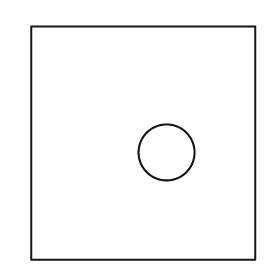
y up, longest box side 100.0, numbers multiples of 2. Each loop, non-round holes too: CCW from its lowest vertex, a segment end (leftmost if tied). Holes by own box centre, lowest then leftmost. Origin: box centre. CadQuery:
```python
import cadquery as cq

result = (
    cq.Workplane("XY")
    .moveTo(-48.0, -50.0)
    .lineTo(48.0, -50.0)
    .lineTo(48.0, 50.0)
    .lineTo(-48.0, 50.0)
    .close()
    .moveTo(10.0, -4.0)
    .circle(12.0)
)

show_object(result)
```